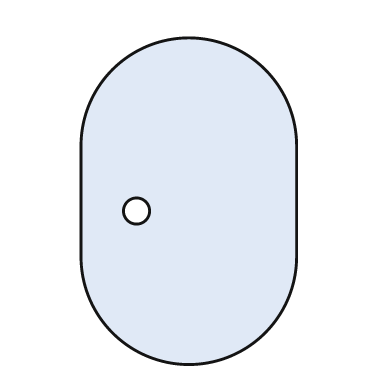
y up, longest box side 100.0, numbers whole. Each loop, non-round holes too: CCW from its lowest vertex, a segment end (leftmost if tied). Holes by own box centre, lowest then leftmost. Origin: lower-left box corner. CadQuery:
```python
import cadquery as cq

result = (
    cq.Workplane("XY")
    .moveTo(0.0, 33.0)
    .threePointArc((33.0, 0.0), (66.0, 33.0))
    .lineTo(66.0, 67.0)
    .threePointArc((33.0, 100.0), (0.0, 67.0))
    .close()
    .moveTo(17.0, 47.0)
    .circle(4.0)
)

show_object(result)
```